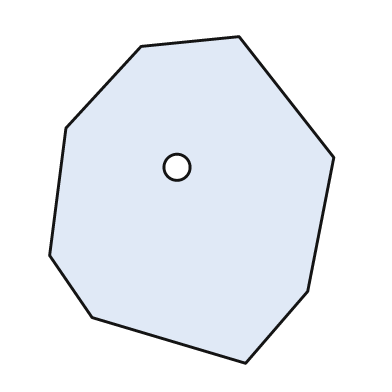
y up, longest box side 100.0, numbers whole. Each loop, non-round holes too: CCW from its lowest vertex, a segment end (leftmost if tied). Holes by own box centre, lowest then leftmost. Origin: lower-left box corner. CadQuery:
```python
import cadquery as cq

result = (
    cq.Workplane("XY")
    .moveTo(60.0, 0.0)
    .lineTo(79.0, 22.0)
    .lineTo(87.0, 63.0)
    .lineTo(58.0, 100.0)
    .lineTo(28.0, 97.0)
    .lineTo(5.0, 72.0)
    .lineTo(0.0, 33.0)
    .lineTo(13.0, 14.0)
    .close()
    .moveTo(39.0, 60.0)
    .circle(4.0)
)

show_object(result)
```